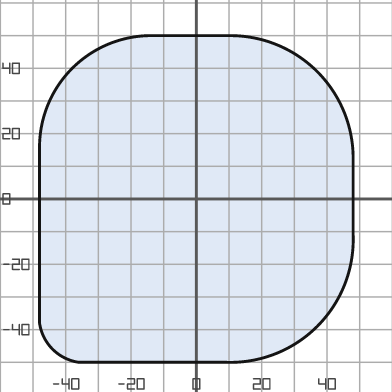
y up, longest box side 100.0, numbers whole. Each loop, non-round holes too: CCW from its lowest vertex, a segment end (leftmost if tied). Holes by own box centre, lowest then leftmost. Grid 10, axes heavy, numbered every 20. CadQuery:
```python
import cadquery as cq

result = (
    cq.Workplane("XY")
    .moveTo(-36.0, -50.0)
    .lineTo(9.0, -50.0)
    .threePointArc((37.0, -39.0), (48.0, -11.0))
    .lineTo(48.0, 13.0)
    .threePointArc((37.0, 39.0), (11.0, 50.0))
    .lineTo(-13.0, 50.0)
    .threePointArc((-38.0, 40.0), (-48.0, 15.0))
    .lineTo(-48.0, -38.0)
    .threePointArc((-44.0, -46.0), (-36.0, -50.0))
    .close()
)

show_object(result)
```